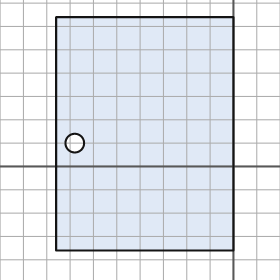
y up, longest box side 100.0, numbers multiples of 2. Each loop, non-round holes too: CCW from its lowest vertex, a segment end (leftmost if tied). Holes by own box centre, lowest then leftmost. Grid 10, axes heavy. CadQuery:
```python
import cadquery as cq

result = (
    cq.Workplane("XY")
    .moveTo(-76.0, -36.0)
    .lineTo(0.0, -36.0)
    .lineTo(0.0, 64.0)
    .lineTo(-76.0, 64.0)
    .close()
    .moveTo(-68.0, 10.0)
    .circle(4.0)
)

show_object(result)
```